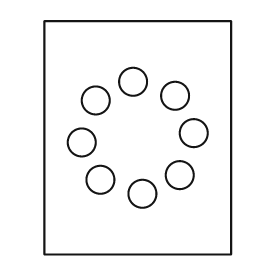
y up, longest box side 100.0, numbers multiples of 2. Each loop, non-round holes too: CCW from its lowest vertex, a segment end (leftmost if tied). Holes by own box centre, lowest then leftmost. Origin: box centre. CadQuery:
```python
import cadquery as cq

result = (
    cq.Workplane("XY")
    .moveTo(-40.0, -50.0)
    .lineTo(40.0, -50.0)
    .lineTo(40.0, 50.0)
    .lineTo(-40.0, 50.0)
    .close()
    .moveTo(2.0, -24.0)
    .circle(6.0)
    .moveTo(-16.0, -18.0)
    .circle(6.0)
    .moveTo(18.0, -16.0)
    .circle(6.0)
    .moveTo(-24.0, -2.0)
    .circle(6.0)
    .moveTo(24.0, 2.0)
    .circle(6.0)
    .moveTo(-18.0, 16.0)
    .circle(6.0)
    .moveTo(16.0, 18.0)
    .circle(6.0)
    .moveTo(-2.0, 24.0)
    .circle(6.0)
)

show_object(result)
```